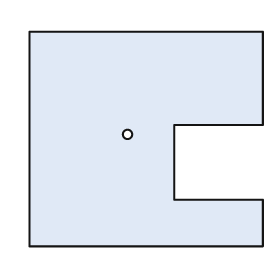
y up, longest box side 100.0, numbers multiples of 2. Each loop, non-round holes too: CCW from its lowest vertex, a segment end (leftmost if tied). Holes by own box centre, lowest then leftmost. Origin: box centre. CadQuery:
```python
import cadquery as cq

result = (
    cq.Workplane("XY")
    .moveTo(-50.0, -46.0)
    .lineTo(50.0, -46.0)
    .lineTo(50.0, -26.0)
    .lineTo(12.0, -26.0)
    .lineTo(12.0, 6.0)
    .lineTo(50.0, 6.0)
    .lineTo(50.0, 46.0)
    .lineTo(-50.0, 46.0)
    .close()
    .moveTo(-8.0, 2.0)
    .circle(2.0)
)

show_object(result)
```